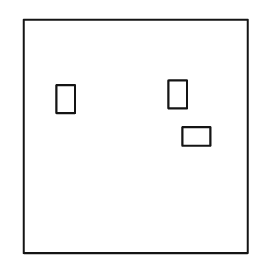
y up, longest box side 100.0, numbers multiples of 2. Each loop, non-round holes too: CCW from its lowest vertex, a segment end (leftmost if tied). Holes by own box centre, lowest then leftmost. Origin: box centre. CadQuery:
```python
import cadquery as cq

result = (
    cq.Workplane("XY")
    .moveTo(-48.0, -50.0)
    .lineTo(48.0, -50.0)
    .lineTo(48.0, 50.0)
    .lineTo(-48.0, 50.0)
    .close()
    .moveTo(20.0, -4.0)
    .lineTo(32.0, -4.0)
    .lineTo(32.0, 4.0)
    .lineTo(20.0, 4.0)
    .close()
    .moveTo(-34.0, 10.0)
    .lineTo(-26.0, 10.0)
    .lineTo(-26.0, 22.0)
    .lineTo(-34.0, 22.0)
    .close()
    .moveTo(14.0, 12.0)
    .lineTo(22.0, 12.0)
    .lineTo(22.0, 24.0)
    .lineTo(14.0, 24.0)
    .close()
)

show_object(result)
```